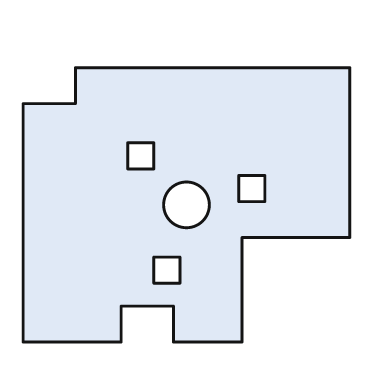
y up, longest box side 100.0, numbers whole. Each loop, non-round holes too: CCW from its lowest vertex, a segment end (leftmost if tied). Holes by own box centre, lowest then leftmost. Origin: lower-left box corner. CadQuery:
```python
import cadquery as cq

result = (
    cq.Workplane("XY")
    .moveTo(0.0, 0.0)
    .lineTo(30.0, 0.0)
    .lineTo(30.0, 11.0)
    .lineTo(46.0, 11.0)
    .lineTo(46.0, 0.0)
    .lineTo(67.0, 0.0)
    .lineTo(67.0, 32.0)
    .lineTo(100.0, 32.0)
    .lineTo(100.0, 84.0)
    .lineTo(16.0, 84.0)
    .lineTo(16.0, 73.0)
    .lineTo(0.0, 73.0)
    .close()
    .moveTo(40.0, 18.0)
    .lineTo(48.0, 18.0)
    .lineTo(48.0, 26.0)
    .lineTo(40.0, 26.0)
    .close()
    .moveTo(50.0, 42.0)
    .circle(7.0)
    .moveTo(66.0, 43.0)
    .lineTo(74.0, 43.0)
    .lineTo(74.0, 51.0)
    .lineTo(66.0, 51.0)
    .close()
    .moveTo(32.0, 53.0)
    .lineTo(40.0, 53.0)
    .lineTo(40.0, 61.0)
    .lineTo(32.0, 61.0)
    .close()
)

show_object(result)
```